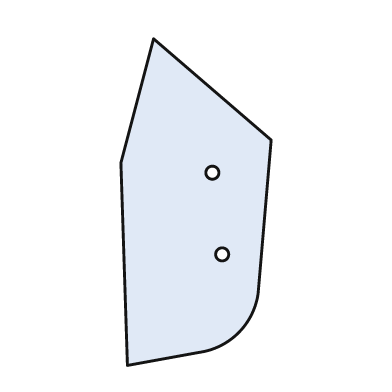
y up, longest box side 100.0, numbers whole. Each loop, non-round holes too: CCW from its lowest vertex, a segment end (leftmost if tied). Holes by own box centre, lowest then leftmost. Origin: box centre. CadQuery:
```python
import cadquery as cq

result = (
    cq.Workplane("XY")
    .moveTo(-21.0, -50.0)
    .lineTo(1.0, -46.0)
    .threePointArc((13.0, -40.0), (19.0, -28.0))
    .lineTo(23.0, 19.0)
    .lineTo(-13.0, 50.0)
    .lineTo(-23.0, 12.0)
    .close()
    .moveTo(8.0, -16.0)
    .circle(2.0)
    .moveTo(5.0, 9.0)
    .circle(2.0)
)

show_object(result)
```